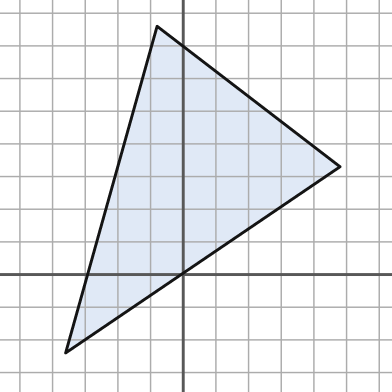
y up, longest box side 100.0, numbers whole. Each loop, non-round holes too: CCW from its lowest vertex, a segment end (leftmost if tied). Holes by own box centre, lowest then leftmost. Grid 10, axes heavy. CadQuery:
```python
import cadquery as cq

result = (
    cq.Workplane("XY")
    .moveTo(-36.0, -24.0)
    .lineTo(48.0, 33.0)
    .lineTo(-8.0, 76.0)
    .close()
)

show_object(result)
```